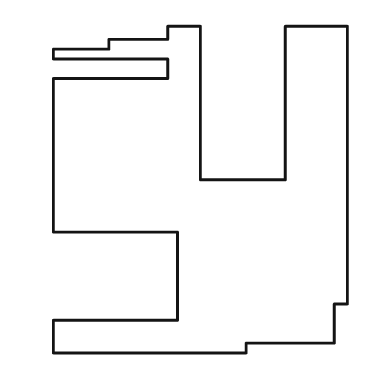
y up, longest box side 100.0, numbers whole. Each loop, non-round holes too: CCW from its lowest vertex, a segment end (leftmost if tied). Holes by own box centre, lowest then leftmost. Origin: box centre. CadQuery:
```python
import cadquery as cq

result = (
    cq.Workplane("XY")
    .moveTo(-45.0, -50.0)
    .lineTo(14.0, -50.0)
    .lineTo(14.0, -47.0)
    .lineTo(41.0, -47.0)
    .lineTo(41.0, -35.0)
    .lineTo(45.0, -35.0)
    .lineTo(45.0, 50.0)
    .lineTo(26.0, 50.0)
    .lineTo(26.0, 3.0)
    .lineTo(0.0, 3.0)
    .lineTo(0.0, 50.0)
    .lineTo(-10.0, 50.0)
    .lineTo(-10.0, 46.0)
    .lineTo(-28.0, 46.0)
    .lineTo(-28.0, 43.0)
    .lineTo(-45.0, 43.0)
    .lineTo(-45.0, 40.0)
    .lineTo(-10.0, 40.0)
    .lineTo(-10.0, 34.0)
    .lineTo(-45.0, 34.0)
    .lineTo(-45.0, -13.0)
    .lineTo(-7.0, -13.0)
    .lineTo(-7.0, -40.0)
    .lineTo(-45.0, -40.0)
    .close()
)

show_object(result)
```